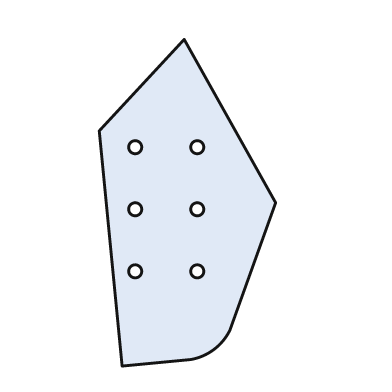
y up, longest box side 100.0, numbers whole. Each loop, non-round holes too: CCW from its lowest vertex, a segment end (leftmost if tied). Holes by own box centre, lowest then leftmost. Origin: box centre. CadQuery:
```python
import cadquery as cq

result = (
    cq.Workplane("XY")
    .moveTo(-20.0, -50.0)
    .lineTo(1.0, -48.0)
    .threePointArc((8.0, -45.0), (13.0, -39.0))
    .lineTo(27.0, 0.0)
    .lineTo(-1.0, 50.0)
    .lineTo(-27.0, 22.0)
    .close()
    .moveTo(-16.0, -21.0)
    .circle(2.0)
    .moveTo(3.0, -21.0)
    .circle(2.0)
    .moveTo(-16.0, -2.0)
    .circle(2.0)
    .moveTo(3.0, -2.0)
    .circle(2.0)
    .moveTo(-16.0, 17.0)
    .circle(2.0)
    .moveTo(3.0, 17.0)
    .circle(2.0)
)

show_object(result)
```